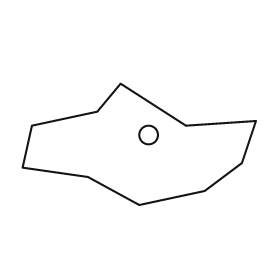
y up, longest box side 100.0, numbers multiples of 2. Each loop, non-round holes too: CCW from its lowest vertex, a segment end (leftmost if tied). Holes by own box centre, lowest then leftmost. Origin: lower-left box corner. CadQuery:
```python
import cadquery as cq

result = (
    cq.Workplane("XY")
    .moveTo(50.0, 0.0)
    .lineTo(78.0, 6.0)
    .lineTo(94.0, 18.0)
    .lineTo(100.0, 36.0)
    .lineTo(70.0, 34.0)
    .lineTo(42.0, 52.0)
    .lineTo(32.0, 40.0)
    .lineTo(4.0, 34.0)
    .lineTo(0.0, 16.0)
    .lineTo(28.0, 12.0)
    .close()
    .moveTo(54.0, 30.0)
    .circle(4.0)
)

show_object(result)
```